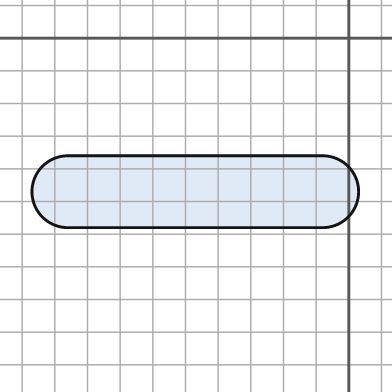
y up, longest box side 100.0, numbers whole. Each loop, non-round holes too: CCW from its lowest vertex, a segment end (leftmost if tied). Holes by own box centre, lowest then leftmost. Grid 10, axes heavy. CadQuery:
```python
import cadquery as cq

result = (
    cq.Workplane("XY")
    .moveTo(-86.0, -58.0)
    .lineTo(-8.0, -58.0)
    .threePointArc((3.0, -47.0), (-8.0, -36.0))
    .lineTo(-86.0, -36.0)
    .threePointArc((-97.0, -47.0), (-86.0, -58.0))
    .close()
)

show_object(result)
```